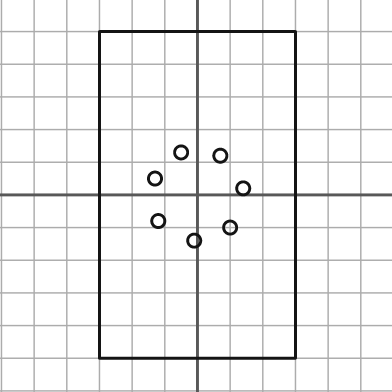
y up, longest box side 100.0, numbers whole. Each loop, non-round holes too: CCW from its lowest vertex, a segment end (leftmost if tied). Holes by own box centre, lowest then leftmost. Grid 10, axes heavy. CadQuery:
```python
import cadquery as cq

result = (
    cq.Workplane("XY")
    .moveTo(-30.0, -50.0)
    .lineTo(30.0, -50.0)
    .lineTo(30.0, 50.0)
    .lineTo(-30.0, 50.0)
    .close()
    .moveTo(-1.0, -14.0)
    .circle(2.0)
    .moveTo(10.0, -10.0)
    .circle(2.0)
    .moveTo(-12.0, -8.0)
    .circle(2.0)
    .moveTo(14.0, 2.0)
    .circle(2.0)
    .moveTo(-13.0, 5.0)
    .circle(2.0)
    .moveTo(7.0, 12.0)
    .circle(2.0)
    .moveTo(-5.0, 13.0)
    .circle(2.0)
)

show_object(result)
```